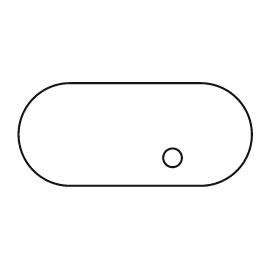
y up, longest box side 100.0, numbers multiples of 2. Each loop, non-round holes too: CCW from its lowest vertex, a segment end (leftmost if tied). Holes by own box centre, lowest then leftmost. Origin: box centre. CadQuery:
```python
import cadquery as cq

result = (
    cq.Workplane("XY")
    .moveTo(-28.0, -22.0)
    .lineTo(28.0, -22.0)
    .threePointArc((50.0, 0.0), (28.0, 22.0))
    .lineTo(-28.0, 22.0)
    .threePointArc((-50.0, 0.0), (-28.0, -22.0))
    .close()
    .moveTo(16.0, -10.0)
    .circle(4.0)
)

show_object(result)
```